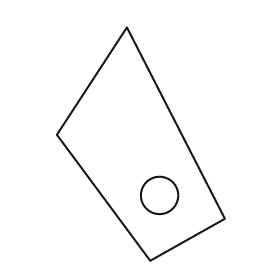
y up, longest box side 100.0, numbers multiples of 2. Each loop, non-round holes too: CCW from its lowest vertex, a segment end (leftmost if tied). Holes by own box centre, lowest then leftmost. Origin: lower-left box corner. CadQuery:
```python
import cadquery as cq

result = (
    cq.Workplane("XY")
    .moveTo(40.0, 0.0)
    .lineTo(72.0, 18.0)
    .lineTo(30.0, 100.0)
    .lineTo(0.0, 54.0)
    .close()
    .moveTo(44.0, 28.0)
    .circle(8.0)
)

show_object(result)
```